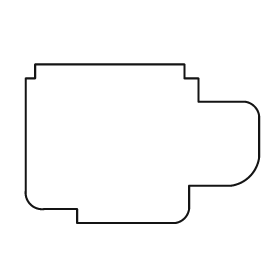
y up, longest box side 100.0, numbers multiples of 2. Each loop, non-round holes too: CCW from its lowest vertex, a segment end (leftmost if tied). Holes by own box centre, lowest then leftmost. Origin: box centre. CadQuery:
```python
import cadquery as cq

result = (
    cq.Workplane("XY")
    .moveTo(-28.0, -34.0)
    .lineTo(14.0, -34.0)
    .threePointArc((18.0, -32.0), (20.0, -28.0))
    .lineTo(20.0, -18.0)
    .lineTo(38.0, -18.0)
    .threePointArc((46.0, -14.0), (50.0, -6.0))
    .lineTo(50.0, 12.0)
    .threePointArc((48.0, 16.0), (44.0, 18.0))
    .lineTo(24.0, 18.0)
    .lineTo(24.0, 28.0)
    .lineTo(18.0, 28.0)
    .lineTo(18.0, 34.0)
    .lineTo(-46.0, 34.0)
    .lineTo(-46.0, 28.0)
    .lineTo(-50.0, 28.0)
    .lineTo(-50.0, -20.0)
    .threePointArc((-48.0, -26.0), (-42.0, -28.0))
    .lineTo(-28.0, -28.0)
    .close()
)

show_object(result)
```